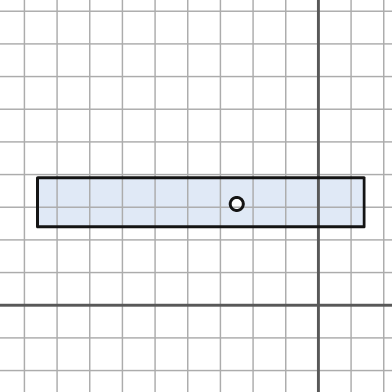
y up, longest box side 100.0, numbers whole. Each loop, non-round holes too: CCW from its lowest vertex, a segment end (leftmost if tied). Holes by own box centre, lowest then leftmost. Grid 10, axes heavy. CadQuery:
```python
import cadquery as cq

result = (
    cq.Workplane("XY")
    .moveTo(-86.0, 24.0)
    .lineTo(14.0, 24.0)
    .lineTo(14.0, 39.0)
    .lineTo(-86.0, 39.0)
    .close()
    .moveTo(-25.0, 31.0)
    .circle(2.0)
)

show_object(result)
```